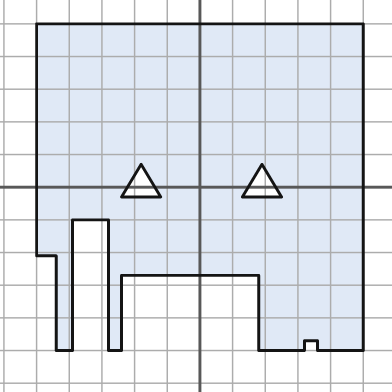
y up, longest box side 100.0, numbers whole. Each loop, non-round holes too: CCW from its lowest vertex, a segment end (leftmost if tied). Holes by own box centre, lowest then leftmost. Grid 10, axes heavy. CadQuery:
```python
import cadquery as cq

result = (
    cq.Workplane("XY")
    .moveTo(-44.0, -50.0)
    .lineTo(-39.0, -50.0)
    .lineTo(-39.0, -10.0)
    .lineTo(-28.0, -10.0)
    .lineTo(-28.0, -50.0)
    .lineTo(-24.0, -50.0)
    .lineTo(-24.0, -27.0)
    .lineTo(18.0, -27.0)
    .lineTo(18.0, -50.0)
    .lineTo(32.0, -50.0)
    .lineTo(32.0, -47.0)
    .lineTo(36.0, -47.0)
    .lineTo(36.0, -50.0)
    .lineTo(50.0, -50.0)
    .lineTo(50.0, 50.0)
    .lineTo(-50.0, 50.0)
    .lineTo(-50.0, -21.0)
    .lineTo(-44.0, -21.0)
    .close()
    .moveTo(-24.0, -3.0)
    .lineTo(-12.0, -3.0)
    .lineTo(-18.0, 7.0)
    .close()
    .moveTo(13.0, -3.0)
    .lineTo(25.0, -3.0)
    .lineTo(19.0, 7.0)
    .close()
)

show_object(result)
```